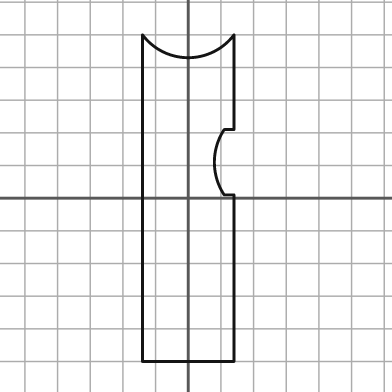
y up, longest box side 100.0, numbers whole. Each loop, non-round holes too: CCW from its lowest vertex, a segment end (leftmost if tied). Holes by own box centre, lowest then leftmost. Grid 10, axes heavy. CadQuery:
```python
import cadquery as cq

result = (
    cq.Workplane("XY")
    .moveTo(-14.0, -50.0)
    .lineTo(14.0, -50.0)
    .lineTo(14.0, 1.0)
    .lineTo(11.0, 1.0)
    .threePointArc((8.0, 11.0), (11.0, 21.0))
    .lineTo(14.0, 21.0)
    .lineTo(14.0, 50.0)
    .threePointArc((0.0, 43.0), (-14.0, 50.0))
    .close()
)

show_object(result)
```